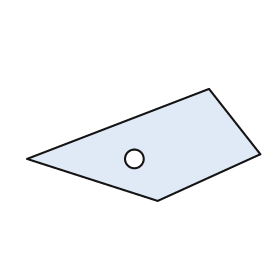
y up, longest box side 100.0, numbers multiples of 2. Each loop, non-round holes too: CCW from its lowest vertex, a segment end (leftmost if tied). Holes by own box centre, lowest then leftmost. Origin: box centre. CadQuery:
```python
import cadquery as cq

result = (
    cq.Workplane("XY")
    .moveTo(6.0, -24.0)
    .lineTo(50.0, -4.0)
    .lineTo(28.0, 24.0)
    .lineTo(-50.0, -6.0)
    .close()
    .moveTo(-4.0, -6.0)
    .circle(4.0)
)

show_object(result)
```